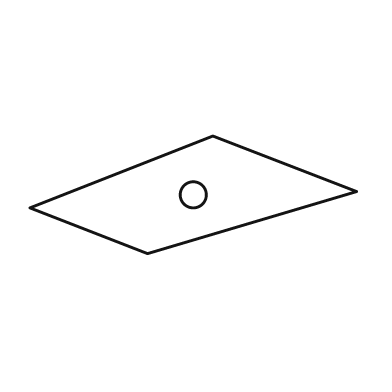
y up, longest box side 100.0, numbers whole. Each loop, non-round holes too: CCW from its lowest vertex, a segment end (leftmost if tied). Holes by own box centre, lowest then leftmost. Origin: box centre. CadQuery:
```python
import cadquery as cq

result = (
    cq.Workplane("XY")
    .moveTo(-14.0, -18.0)
    .lineTo(50.0, 1.0)
    .lineTo(6.0, 18.0)
    .lineTo(-50.0, -4.0)
    .close()
    .moveTo(0.0, 0.0)
    .circle(4.0)
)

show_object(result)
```